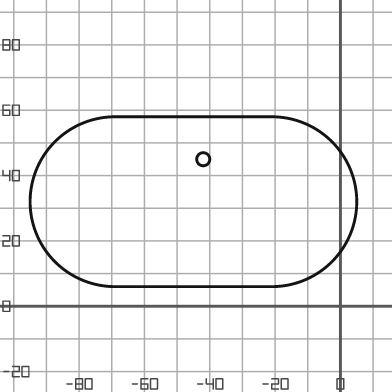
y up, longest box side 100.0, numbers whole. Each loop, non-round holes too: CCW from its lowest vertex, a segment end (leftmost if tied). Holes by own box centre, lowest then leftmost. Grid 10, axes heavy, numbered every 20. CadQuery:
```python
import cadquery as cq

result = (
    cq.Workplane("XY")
    .moveTo(-69.0, 6.0)
    .lineTo(-21.0, 6.0)
    .threePointArc((5.0, 32.0), (-21.0, 58.0))
    .lineTo(-69.0, 58.0)
    .threePointArc((-95.0, 32.0), (-69.0, 6.0))
    .close()
    .moveTo(-42.0, 45.0)
    .circle(2.0)
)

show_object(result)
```